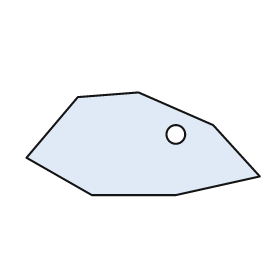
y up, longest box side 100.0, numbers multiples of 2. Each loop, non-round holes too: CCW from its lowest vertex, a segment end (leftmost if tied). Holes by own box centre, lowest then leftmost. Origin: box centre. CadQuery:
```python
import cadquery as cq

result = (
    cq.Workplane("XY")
    .moveTo(-22.0, -22.0)
    .lineTo(14.0, -22.0)
    .lineTo(50.0, -14.0)
    .lineTo(30.0, 8.0)
    .lineTo(-2.0, 22.0)
    .lineTo(-28.0, 20.0)
    .lineTo(-50.0, -6.0)
    .close()
    .moveTo(14.0, 4.0)
    .circle(4.0)
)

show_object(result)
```